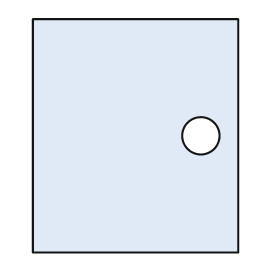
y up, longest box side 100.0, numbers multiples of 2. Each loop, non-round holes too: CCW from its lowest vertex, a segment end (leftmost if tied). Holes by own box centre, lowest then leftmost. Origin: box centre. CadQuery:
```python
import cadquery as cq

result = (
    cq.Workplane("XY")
    .moveTo(-44.0, -50.0)
    .lineTo(44.0, -50.0)
    .lineTo(44.0, 50.0)
    .lineTo(-44.0, 50.0)
    .close()
    .moveTo(28.0, 0.0)
    .circle(8.0)
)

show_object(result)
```